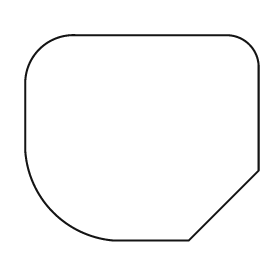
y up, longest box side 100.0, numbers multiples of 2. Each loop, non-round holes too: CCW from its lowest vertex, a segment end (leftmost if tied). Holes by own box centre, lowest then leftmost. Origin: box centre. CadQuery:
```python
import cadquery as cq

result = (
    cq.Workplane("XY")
    .moveTo(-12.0, -44.0)
    .lineTo(20.0, -44.0)
    .lineTo(50.0, -14.0)
    .lineTo(50.0, 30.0)
    .threePointArc((46.0, 40.0), (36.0, 44.0))
    .lineTo(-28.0, 44.0)
    .threePointArc((-44.0, 38.0), (-50.0, 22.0))
    .lineTo(-50.0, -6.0)
    .threePointArc((-38.0, -32.0), (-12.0, -44.0))
    .close()
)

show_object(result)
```